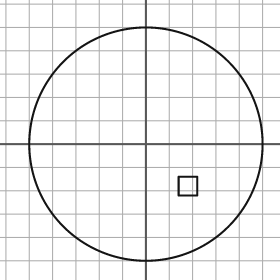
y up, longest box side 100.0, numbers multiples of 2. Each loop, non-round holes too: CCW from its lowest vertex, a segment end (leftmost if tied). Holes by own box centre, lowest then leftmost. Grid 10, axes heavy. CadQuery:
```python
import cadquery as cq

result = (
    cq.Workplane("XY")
    .moveTo(0.0, 0.0)
    .circle(50.0)
    .moveTo(14.0, -22.0)
    .lineTo(22.0, -22.0)
    .lineTo(22.0, -14.0)
    .lineTo(14.0, -14.0)
    .close()
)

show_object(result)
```